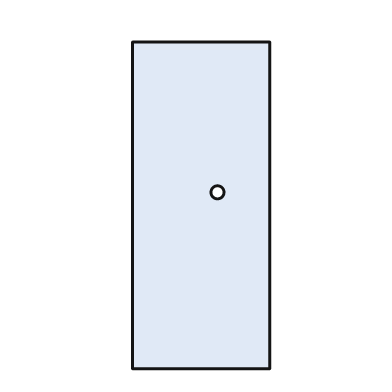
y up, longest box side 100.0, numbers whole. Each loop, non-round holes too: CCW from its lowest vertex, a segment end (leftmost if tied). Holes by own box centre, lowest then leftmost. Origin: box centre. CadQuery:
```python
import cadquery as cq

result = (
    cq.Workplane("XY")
    .moveTo(-21.0, -50.0)
    .lineTo(21.0, -50.0)
    .lineTo(21.0, 50.0)
    .lineTo(-21.0, 50.0)
    .close()
    .moveTo(5.0, 4.0)
    .circle(2.0)
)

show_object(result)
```